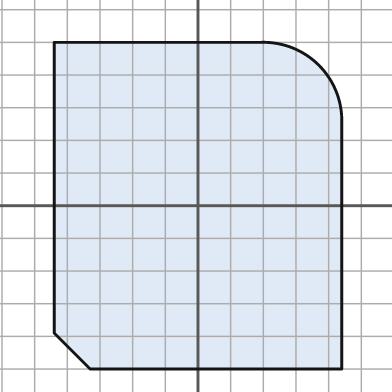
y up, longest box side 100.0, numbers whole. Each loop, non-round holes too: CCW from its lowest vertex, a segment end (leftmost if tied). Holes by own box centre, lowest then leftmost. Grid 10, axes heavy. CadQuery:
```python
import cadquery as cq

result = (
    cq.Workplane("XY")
    .moveTo(-33.0, -50.0)
    .lineTo(44.0, -50.0)
    .lineTo(44.0, 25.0)
    .threePointArc((37.0, 43.0), (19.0, 50.0))
    .lineTo(-44.0, 50.0)
    .lineTo(-44.0, -39.0)
    .close()
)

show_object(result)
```